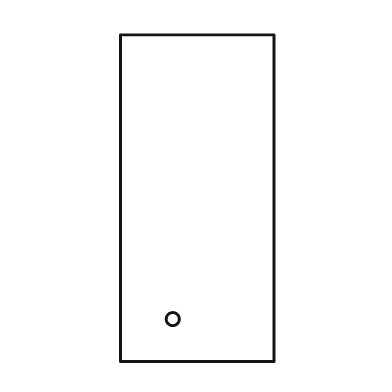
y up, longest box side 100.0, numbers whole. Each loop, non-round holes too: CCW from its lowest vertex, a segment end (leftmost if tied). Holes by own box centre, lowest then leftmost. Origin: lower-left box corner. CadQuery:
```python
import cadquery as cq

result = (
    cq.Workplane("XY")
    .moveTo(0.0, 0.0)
    .lineTo(47.0, 0.0)
    .lineTo(47.0, 100.0)
    .lineTo(0.0, 100.0)
    .close()
    .moveTo(16.0, 13.0)
    .circle(2.0)
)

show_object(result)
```